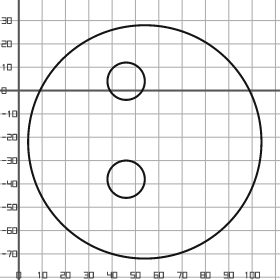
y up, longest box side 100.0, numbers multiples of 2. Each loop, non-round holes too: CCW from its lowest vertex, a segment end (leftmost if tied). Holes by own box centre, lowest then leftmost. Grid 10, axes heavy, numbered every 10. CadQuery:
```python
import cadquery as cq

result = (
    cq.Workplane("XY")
    .moveTo(54.0, -22.0)
    .circle(50.0)
    .moveTo(46.0, -38.0)
    .circle(8.0)
    .moveTo(46.0, 4.0)
    .circle(8.0)
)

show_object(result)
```